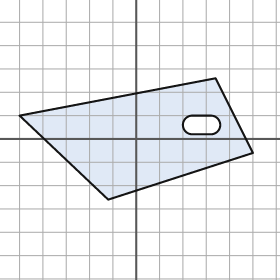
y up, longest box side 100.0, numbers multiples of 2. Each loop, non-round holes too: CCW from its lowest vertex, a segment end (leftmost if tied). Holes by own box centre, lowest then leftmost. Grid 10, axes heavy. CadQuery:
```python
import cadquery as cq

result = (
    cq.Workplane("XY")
    .moveTo(-12.0, -26.0)
    .lineTo(50.0, -6.0)
    .lineTo(34.0, 26.0)
    .lineTo(-50.0, 10.0)
    .close()
    .moveTo(24.0, 2.0)
    .lineTo(32.0, 2.0)
    .threePointArc((36.0, 6.0), (32.0, 10.0))
    .lineTo(24.0, 10.0)
    .threePointArc((20.0, 6.0), (24.0, 2.0))
    .close()
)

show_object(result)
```